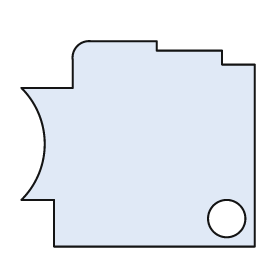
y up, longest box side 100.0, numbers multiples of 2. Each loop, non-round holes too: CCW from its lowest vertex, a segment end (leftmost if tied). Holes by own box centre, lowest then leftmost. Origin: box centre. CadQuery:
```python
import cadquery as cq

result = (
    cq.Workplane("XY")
    .moveTo(-36.0, -44.0)
    .lineTo(50.0, -44.0)
    .lineTo(50.0, 34.0)
    .lineTo(36.0, 34.0)
    .lineTo(36.0, 40.0)
    .lineTo(8.0, 40.0)
    .lineTo(8.0, 44.0)
    .lineTo(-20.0, 44.0)
    .threePointArc((-26.0, 42.0), (-28.0, 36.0))
    .lineTo(-28.0, 24.0)
    .lineTo(-50.0, 24.0)
    .threePointArc((-40.0, 0.0), (-50.0, -24.0))
    .lineTo(-36.0, -24.0)
    .close()
    .moveTo(38.0, -32.0)
    .circle(8.0)
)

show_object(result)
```